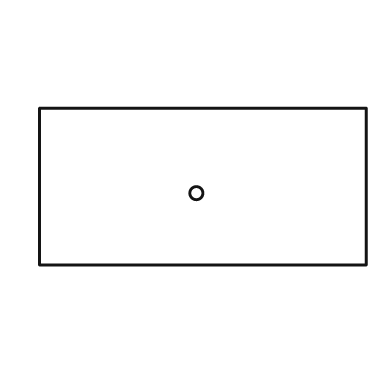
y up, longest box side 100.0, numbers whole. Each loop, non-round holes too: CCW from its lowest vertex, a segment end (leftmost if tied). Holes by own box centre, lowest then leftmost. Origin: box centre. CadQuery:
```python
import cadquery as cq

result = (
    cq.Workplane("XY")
    .moveTo(-50.0, -24.0)
    .lineTo(50.0, -24.0)
    .lineTo(50.0, 24.0)
    .lineTo(-50.0, 24.0)
    .close()
    .moveTo(-2.0, -2.0)
    .circle(2.0)
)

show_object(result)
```